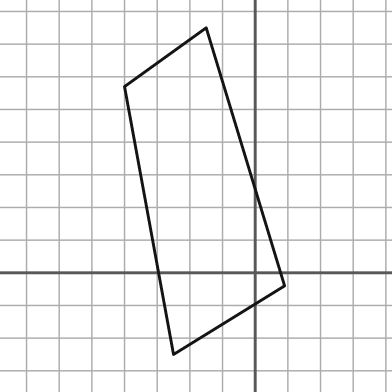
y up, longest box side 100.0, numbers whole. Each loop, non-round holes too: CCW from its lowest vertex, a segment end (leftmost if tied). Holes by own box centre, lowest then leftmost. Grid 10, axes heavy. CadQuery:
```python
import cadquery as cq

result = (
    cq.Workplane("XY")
    .moveTo(-25.0, -25.0)
    .lineTo(9.0, -4.0)
    .lineTo(-15.0, 75.0)
    .lineTo(-40.0, 57.0)
    .close()
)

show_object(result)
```